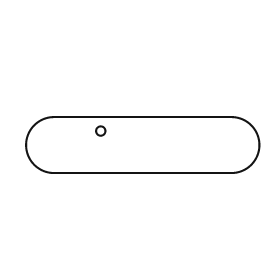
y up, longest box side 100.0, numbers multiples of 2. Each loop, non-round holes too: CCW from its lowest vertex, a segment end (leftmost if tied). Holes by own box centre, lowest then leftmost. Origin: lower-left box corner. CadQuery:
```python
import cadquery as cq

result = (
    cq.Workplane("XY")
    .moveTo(12.0, 0.0)
    .lineTo(88.0, 0.0)
    .threePointArc((100.0, 12.0), (88.0, 24.0))
    .lineTo(12.0, 24.0)
    .threePointArc((0.0, 12.0), (12.0, 0.0))
    .close()
    .moveTo(32.0, 18.0)
    .circle(2.0)
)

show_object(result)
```